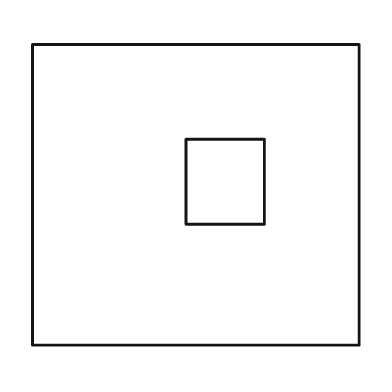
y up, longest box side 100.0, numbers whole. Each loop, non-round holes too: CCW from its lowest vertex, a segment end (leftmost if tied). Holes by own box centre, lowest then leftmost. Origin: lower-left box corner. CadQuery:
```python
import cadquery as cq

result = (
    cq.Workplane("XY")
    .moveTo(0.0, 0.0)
    .lineTo(100.0, 0.0)
    .lineTo(100.0, 92.0)
    .lineTo(0.0, 92.0)
    .close()
    .moveTo(47.0, 37.0)
    .lineTo(71.0, 37.0)
    .lineTo(71.0, 63.0)
    .lineTo(47.0, 63.0)
    .close()
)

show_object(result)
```